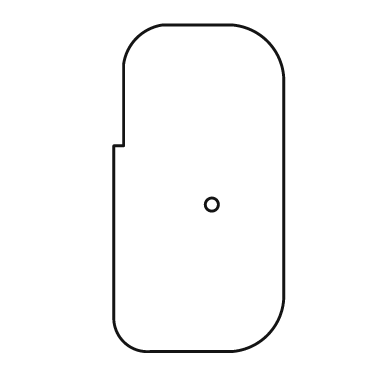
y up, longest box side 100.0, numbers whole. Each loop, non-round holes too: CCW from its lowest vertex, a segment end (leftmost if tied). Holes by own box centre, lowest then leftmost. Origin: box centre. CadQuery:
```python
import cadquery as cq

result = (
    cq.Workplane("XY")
    .moveTo(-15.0, -50.0)
    .lineTo(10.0, -50.0)
    .threePointArc((21.0, -45.0), (26.0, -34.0))
    .lineTo(26.0, 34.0)
    .threePointArc((21.0, 45.0), (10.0, 50.0))
    .lineTo(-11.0, 50.0)
    .threePointArc((-19.0, 46.0), (-23.0, 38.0))
    .lineTo(-23.0, 13.0)
    .lineTo(-26.0, 13.0)
    .lineTo(-26.0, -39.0)
    .threePointArc((-23.0, -47.0), (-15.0, -50.0))
    .close()
    .moveTo(4.0, -5.0)
    .circle(2.0)
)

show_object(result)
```